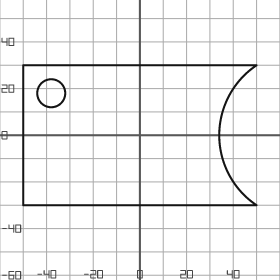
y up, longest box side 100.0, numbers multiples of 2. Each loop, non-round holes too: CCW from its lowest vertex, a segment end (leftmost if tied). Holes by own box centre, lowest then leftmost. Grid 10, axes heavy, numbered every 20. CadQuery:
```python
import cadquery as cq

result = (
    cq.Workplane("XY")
    .moveTo(-50.0, -30.0)
    .lineTo(50.0, -30.0)
    .threePointArc((34.0, 0.0), (50.0, 30.0))
    .lineTo(-50.0, 30.0)
    .close()
    .moveTo(-38.0, 18.0)
    .circle(6.0)
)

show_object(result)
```